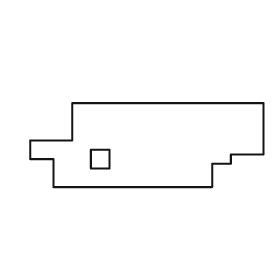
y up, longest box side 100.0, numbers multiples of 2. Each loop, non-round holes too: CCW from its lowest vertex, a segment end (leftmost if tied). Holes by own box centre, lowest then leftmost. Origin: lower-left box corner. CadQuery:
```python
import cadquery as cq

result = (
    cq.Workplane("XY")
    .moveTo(10.0, 0.0)
    .lineTo(78.0, 0.0)
    .lineTo(78.0, 10.0)
    .lineTo(86.0, 10.0)
    .lineTo(86.0, 14.0)
    .lineTo(100.0, 14.0)
    .lineTo(100.0, 36.0)
    .lineTo(18.0, 36.0)
    .lineTo(18.0, 20.0)
    .lineTo(0.0, 20.0)
    .lineTo(0.0, 12.0)
    .lineTo(10.0, 12.0)
    .close()
    .moveTo(26.0, 8.0)
    .lineTo(34.0, 8.0)
    .lineTo(34.0, 16.0)
    .lineTo(26.0, 16.0)
    .close()
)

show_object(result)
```